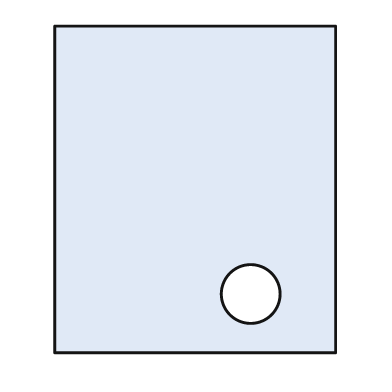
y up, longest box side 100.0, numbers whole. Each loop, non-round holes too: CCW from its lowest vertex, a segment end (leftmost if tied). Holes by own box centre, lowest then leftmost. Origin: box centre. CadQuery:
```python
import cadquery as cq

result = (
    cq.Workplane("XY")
    .moveTo(-43.0, -50.0)
    .lineTo(43.0, -50.0)
    .lineTo(43.0, 50.0)
    .lineTo(-43.0, 50.0)
    .close()
    .moveTo(17.0, -32.0)
    .circle(9.0)
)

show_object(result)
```